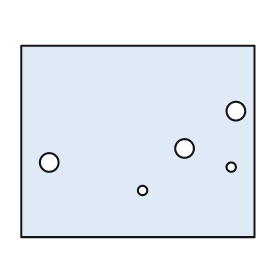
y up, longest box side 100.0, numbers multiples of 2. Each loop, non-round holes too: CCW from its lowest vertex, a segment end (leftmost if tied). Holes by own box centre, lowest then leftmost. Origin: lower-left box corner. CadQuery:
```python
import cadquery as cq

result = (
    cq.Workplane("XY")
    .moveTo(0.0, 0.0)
    .lineTo(100.0, 0.0)
    .lineTo(100.0, 82.0)
    .lineTo(0.0, 82.0)
    .close()
    .moveTo(52.0, 20.0)
    .circle(2.0)
    .moveTo(90.0, 30.0)
    .circle(2.0)
    .moveTo(12.0, 32.0)
    .circle(4.0)
    .moveTo(70.0, 38.0)
    .circle(4.0)
    .moveTo(92.0, 54.0)
    .circle(4.0)
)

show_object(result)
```